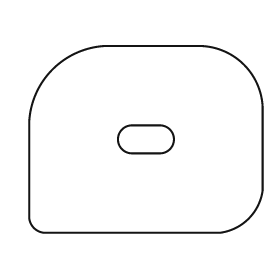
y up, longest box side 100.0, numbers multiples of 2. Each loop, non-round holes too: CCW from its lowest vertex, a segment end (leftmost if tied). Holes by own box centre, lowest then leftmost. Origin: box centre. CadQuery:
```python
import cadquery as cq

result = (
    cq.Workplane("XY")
    .moveTo(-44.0, -40.0)
    .lineTo(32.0, -40.0)
    .threePointArc((44.0, -34.0), (50.0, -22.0))
    .lineTo(50.0, 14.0)
    .threePointArc((42.0, 32.0), (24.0, 40.0))
    .lineTo(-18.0, 40.0)
    .threePointArc((-40.0, 30.0), (-50.0, 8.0))
    .lineTo(-50.0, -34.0)
    .threePointArc((-48.0, -38.0), (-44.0, -40.0))
    .close()
    .moveTo(-6.0, -6.0)
    .lineTo(6.0, -6.0)
    .threePointArc((12.0, 0.0), (6.0, 6.0))
    .lineTo(-6.0, 6.0)
    .threePointArc((-12.0, 0.0), (-6.0, -6.0))
    .close()
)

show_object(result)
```